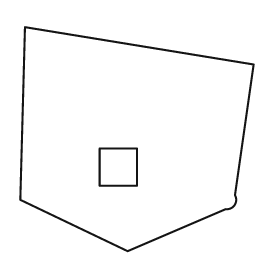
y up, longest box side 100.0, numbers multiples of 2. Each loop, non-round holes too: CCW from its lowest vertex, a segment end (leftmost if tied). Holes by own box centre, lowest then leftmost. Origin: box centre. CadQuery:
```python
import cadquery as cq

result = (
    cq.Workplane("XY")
    .moveTo(-4.0, -48.0)
    .lineTo(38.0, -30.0)
    .threePointArc((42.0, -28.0), (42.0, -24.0))
    .lineTo(50.0, 32.0)
    .lineTo(-48.0, 48.0)
    .lineTo(-50.0, -26.0)
    .close()
    .moveTo(-16.0, -20.0)
    .lineTo(0.0, -20.0)
    .lineTo(0.0, -4.0)
    .lineTo(-16.0, -4.0)
    .close()
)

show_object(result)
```